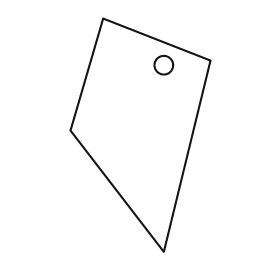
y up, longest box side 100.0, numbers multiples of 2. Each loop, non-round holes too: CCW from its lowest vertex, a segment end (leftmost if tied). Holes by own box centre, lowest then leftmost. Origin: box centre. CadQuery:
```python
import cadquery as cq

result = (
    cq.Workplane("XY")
    .moveTo(10.0, -50.0)
    .lineTo(30.0, 32.0)
    .lineTo(-16.0, 50.0)
    .lineTo(-30.0, 2.0)
    .close()
    .moveTo(10.0, 30.0)
    .circle(4.0)
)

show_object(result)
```